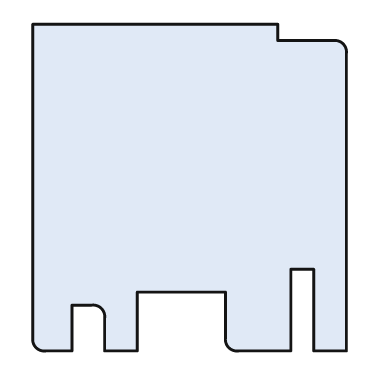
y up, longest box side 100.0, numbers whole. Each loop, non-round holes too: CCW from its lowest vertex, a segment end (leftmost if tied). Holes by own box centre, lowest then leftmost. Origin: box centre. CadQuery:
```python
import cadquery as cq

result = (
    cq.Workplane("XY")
    .moveTo(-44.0, -50.0)
    .lineTo(-36.0, -50.0)
    .lineTo(-36.0, -36.0)
    .lineTo(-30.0, -36.0)
    .threePointArc((-27.0, -37.0), (-26.0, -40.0))
    .lineTo(-26.0, -50.0)
    .lineTo(-16.0, -50.0)
    .lineTo(-16.0, -32.0)
    .lineTo(11.0, -32.0)
    .lineTo(11.0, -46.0)
    .threePointArc((12.0, -49.0), (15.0, -50.0))
    .lineTo(31.0, -50.0)
    .lineTo(31.0, -25.0)
    .lineTo(38.0, -25.0)
    .lineTo(38.0, -50.0)
    .lineTo(48.0, -50.0)
    .lineTo(48.0, 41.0)
    .threePointArc((47.0, 44.0), (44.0, 45.0))
    .lineTo(27.0, 45.0)
    .lineTo(27.0, 50.0)
    .lineTo(-48.0, 50.0)
    .lineTo(-48.0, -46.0)
    .threePointArc((-47.0, -49.0), (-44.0, -50.0))
    .close()
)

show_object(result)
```